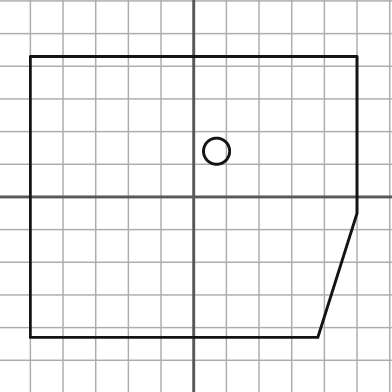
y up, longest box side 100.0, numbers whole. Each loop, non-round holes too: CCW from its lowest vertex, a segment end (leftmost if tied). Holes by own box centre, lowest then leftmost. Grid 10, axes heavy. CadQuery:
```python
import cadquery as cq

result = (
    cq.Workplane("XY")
    .moveTo(-50.0, -43.0)
    .lineTo(38.0, -43.0)
    .lineTo(50.0, -5.0)
    .lineTo(50.0, 43.0)
    .lineTo(-50.0, 43.0)
    .close()
    .moveTo(7.0, 14.0)
    .circle(4.0)
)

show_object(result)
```